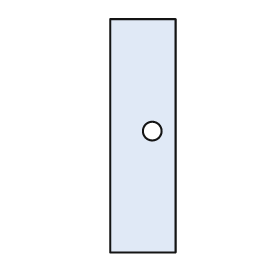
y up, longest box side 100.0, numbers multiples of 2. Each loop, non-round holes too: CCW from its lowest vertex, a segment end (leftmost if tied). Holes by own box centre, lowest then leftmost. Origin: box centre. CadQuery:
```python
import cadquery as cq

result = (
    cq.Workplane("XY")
    .moveTo(-14.0, -50.0)
    .lineTo(14.0, -50.0)
    .lineTo(14.0, 50.0)
    .lineTo(-14.0, 50.0)
    .close()
    .moveTo(4.0, 2.0)
    .circle(4.0)
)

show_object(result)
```